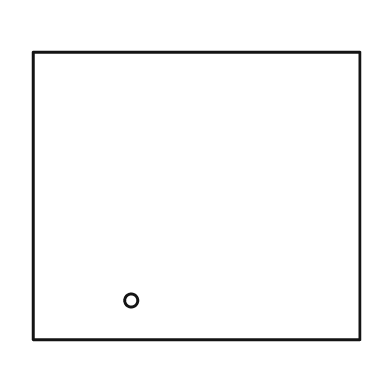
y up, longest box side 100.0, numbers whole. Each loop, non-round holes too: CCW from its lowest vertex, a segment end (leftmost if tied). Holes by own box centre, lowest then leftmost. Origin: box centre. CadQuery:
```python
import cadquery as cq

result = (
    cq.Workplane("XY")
    .moveTo(-50.0, -44.0)
    .lineTo(50.0, -44.0)
    .lineTo(50.0, 44.0)
    .lineTo(-50.0, 44.0)
    .close()
    .moveTo(-20.0, -32.0)
    .circle(2.0)
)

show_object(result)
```